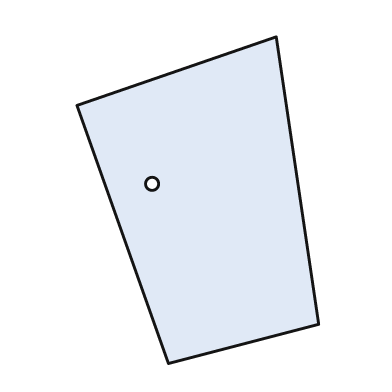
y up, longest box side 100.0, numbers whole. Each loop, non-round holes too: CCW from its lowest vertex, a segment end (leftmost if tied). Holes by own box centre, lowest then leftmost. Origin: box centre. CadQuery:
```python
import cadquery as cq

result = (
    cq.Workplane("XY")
    .moveTo(-9.0, -50.0)
    .lineTo(37.0, -38.0)
    .lineTo(24.0, 50.0)
    .lineTo(-37.0, 29.0)
    .close()
    .moveTo(-14.0, 5.0)
    .circle(2.0)
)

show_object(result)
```